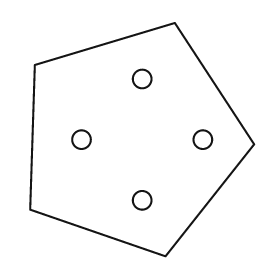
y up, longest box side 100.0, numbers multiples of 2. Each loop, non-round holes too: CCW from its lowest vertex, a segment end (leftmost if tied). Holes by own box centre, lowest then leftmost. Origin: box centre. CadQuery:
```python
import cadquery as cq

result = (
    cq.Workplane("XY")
    .moveTo(10.0, -50.0)
    .lineTo(48.0, -2.0)
    .lineTo(14.0, 50.0)
    .lineTo(-46.0, 32.0)
    .lineTo(-48.0, -30.0)
    .close()
    .moveTo(0.0, -26.0)
    .circle(4.0)
    .moveTo(-26.0, 0.0)
    .circle(4.0)
    .moveTo(26.0, 0.0)
    .circle(4.0)
    .moveTo(0.0, 26.0)
    .circle(4.0)
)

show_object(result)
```